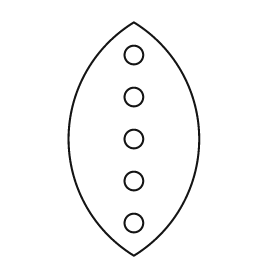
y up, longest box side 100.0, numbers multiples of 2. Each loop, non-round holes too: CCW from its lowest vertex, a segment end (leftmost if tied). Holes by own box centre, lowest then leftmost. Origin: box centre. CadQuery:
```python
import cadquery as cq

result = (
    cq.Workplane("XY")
    .moveTo(0.0, -50.0)
    .threePointArc((28.0, 0.0), (0.0, 50.0))
    .threePointArc((-28.0, 0.0), (0.0, -50.0))
    .close()
    .moveTo(0.0, -36.0)
    .circle(4.0)
    .moveTo(0.0, -18.0)
    .circle(4.0)
    .moveTo(0.0, 0.0)
    .circle(4.0)
    .moveTo(0.0, 18.0)
    .circle(4.0)
    .moveTo(0.0, 36.0)
    .circle(4.0)
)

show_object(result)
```